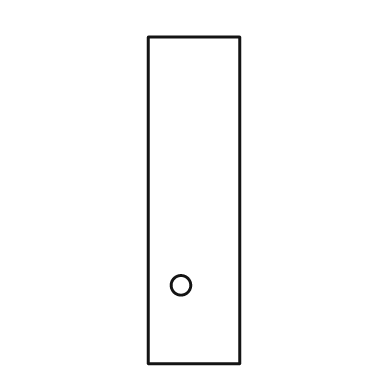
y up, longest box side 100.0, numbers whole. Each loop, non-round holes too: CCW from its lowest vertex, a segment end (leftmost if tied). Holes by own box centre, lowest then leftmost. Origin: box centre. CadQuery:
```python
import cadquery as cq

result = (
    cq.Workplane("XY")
    .moveTo(-14.0, -50.0)
    .lineTo(14.0, -50.0)
    .lineTo(14.0, 50.0)
    .lineTo(-14.0, 50.0)
    .close()
    .moveTo(-4.0, -26.0)
    .circle(3.0)
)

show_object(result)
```